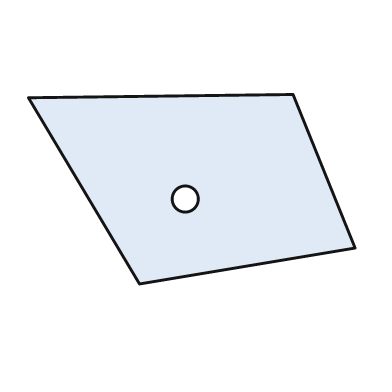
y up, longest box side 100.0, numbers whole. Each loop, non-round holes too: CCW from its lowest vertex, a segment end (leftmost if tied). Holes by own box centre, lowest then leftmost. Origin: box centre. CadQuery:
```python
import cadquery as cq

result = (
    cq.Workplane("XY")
    .moveTo(-16.0, -29.0)
    .lineTo(50.0, -18.0)
    .lineTo(31.0, 29.0)
    .lineTo(-50.0, 28.0)
    .close()
    .moveTo(-2.0, -3.0)
    .circle(4.0)
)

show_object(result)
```